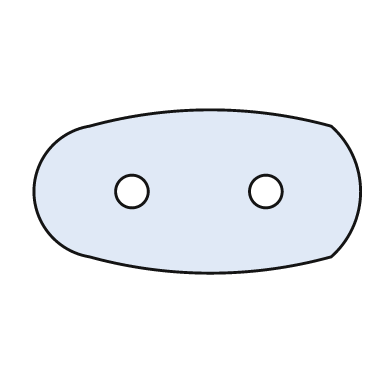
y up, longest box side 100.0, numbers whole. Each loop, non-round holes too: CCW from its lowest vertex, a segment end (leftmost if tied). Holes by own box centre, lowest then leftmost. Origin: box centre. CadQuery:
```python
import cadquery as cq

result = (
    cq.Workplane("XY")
    .moveTo(-33.0, -20.0)
    .threePointArc((4.0, -25.0), (41.0, -20.0))
    .threePointArc((50.0, 0.0), (41.0, 20.0))
    .threePointArc((4.0, 25.0), (-33.0, 20.0))
    .threePointArc((-50.0, 0.0), (-33.0, -20.0))
    .close()
    .moveTo(-20.0, 0.0)
    .circle(5.0)
    .moveTo(21.0, 0.0)
    .circle(5.0)
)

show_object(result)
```